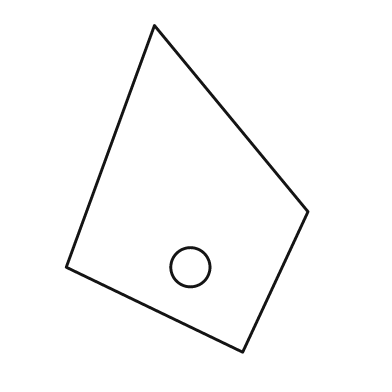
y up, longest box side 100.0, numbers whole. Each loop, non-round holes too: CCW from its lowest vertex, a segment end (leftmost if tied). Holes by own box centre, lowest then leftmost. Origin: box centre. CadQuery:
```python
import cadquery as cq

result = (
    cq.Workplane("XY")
    .moveTo(17.0, -50.0)
    .lineTo(37.0, -7.0)
    .lineTo(-10.0, 50.0)
    .lineTo(-37.0, -24.0)
    .close()
    .moveTo(1.0, -24.0)
    .circle(6.0)
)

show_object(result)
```